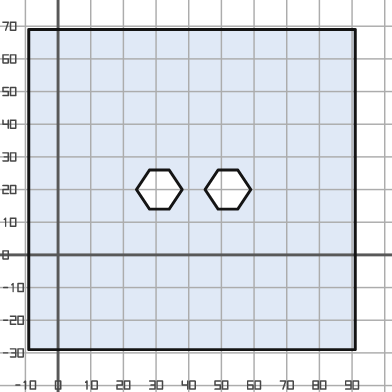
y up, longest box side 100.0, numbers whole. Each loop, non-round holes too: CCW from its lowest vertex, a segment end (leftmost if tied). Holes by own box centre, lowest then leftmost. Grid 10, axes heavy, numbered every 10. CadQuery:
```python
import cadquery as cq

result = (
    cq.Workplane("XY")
    .moveTo(-9.0, -29.0)
    .lineTo(91.0, -29.0)
    .lineTo(91.0, 69.0)
    .lineTo(-9.0, 69.0)
    .close()
    .moveTo(28.0, 14.0)
    .lineTo(34.0, 14.0)
    .lineTo(38.0, 20.0)
    .lineTo(34.0, 26.0)
    .lineTo(28.0, 26.0)
    .lineTo(24.0, 20.0)
    .close()
    .moveTo(49.0, 14.0)
    .lineTo(55.0, 14.0)
    .lineTo(59.0, 20.0)
    .lineTo(55.0, 26.0)
    .lineTo(49.0, 26.0)
    .lineTo(45.0, 20.0)
    .close()
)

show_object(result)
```